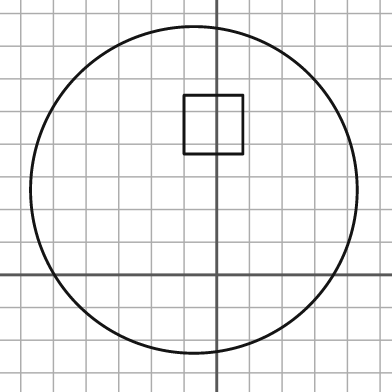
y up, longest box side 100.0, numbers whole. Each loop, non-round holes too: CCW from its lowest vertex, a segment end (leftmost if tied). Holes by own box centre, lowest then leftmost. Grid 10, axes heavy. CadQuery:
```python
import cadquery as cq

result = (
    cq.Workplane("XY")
    .moveTo(-7.0, 26.0)
    .circle(50.0)
    .moveTo(-10.0, 37.0)
    .lineTo(8.0, 37.0)
    .lineTo(8.0, 55.0)
    .lineTo(-10.0, 55.0)
    .close()
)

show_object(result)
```